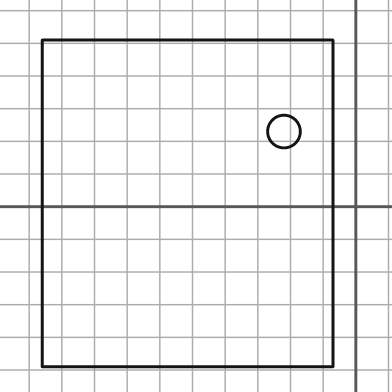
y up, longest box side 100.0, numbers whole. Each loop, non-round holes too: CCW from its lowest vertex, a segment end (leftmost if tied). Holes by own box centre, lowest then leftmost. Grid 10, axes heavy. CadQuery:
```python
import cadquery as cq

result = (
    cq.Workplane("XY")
    .moveTo(-96.0, -49.0)
    .lineTo(-7.0, -49.0)
    .lineTo(-7.0, 51.0)
    .lineTo(-96.0, 51.0)
    .close()
    .moveTo(-22.0, 23.0)
    .circle(5.0)
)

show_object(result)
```